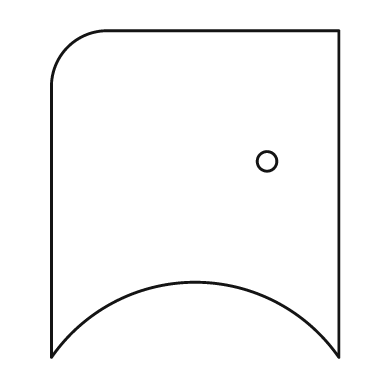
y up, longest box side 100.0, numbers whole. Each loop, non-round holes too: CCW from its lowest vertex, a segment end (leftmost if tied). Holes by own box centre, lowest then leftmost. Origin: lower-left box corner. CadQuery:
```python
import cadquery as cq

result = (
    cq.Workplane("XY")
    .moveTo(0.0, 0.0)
    .threePointArc((44.0, 23.0), (88.0, 0.0))
    .lineTo(88.0, 100.0)
    .lineTo(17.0, 100.0)
    .threePointArc((5.0, 95.0), (0.0, 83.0))
    .close()
    .moveTo(66.0, 60.0)
    .circle(3.0)
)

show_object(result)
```